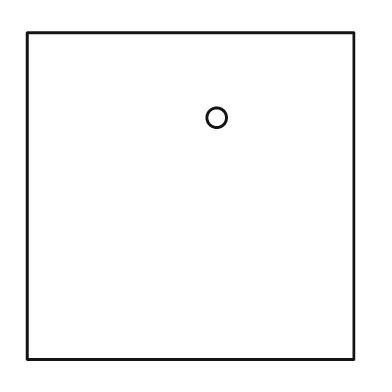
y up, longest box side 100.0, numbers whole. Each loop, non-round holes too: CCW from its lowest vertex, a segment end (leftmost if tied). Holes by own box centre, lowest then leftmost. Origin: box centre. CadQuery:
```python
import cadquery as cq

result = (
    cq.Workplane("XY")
    .moveTo(-50.0, -50.0)
    .lineTo(50.0, -50.0)
    .lineTo(50.0, 50.0)
    .lineTo(-50.0, 50.0)
    .close()
    .moveTo(8.0, 24.0)
    .circle(3.0)
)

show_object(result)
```